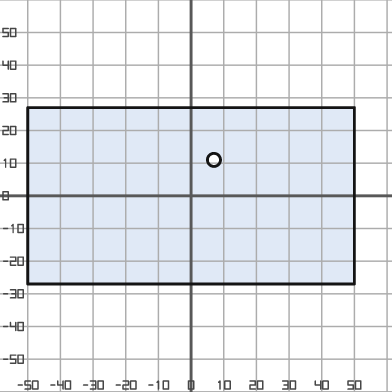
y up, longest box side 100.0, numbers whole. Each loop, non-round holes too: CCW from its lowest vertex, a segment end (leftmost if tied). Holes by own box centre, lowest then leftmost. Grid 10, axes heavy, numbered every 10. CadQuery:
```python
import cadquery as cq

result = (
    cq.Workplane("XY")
    .moveTo(-50.0, -27.0)
    .lineTo(50.0, -27.0)
    .lineTo(50.0, 27.0)
    .lineTo(-50.0, 27.0)
    .close()
    .moveTo(7.0, 11.0)
    .circle(2.0)
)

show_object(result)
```